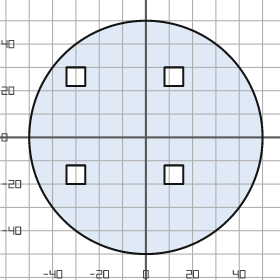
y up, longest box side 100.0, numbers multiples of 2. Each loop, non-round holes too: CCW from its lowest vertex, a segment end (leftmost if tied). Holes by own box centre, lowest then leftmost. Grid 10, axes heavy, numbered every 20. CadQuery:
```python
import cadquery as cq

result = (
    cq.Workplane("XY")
    .moveTo(0.0, 0.0)
    .circle(50.0)
    .moveTo(-34.0, -20.0)
    .lineTo(-26.0, -20.0)
    .lineTo(-26.0, -12.0)
    .lineTo(-34.0, -12.0)
    .close()
    .moveTo(8.0, -20.0)
    .lineTo(16.0, -20.0)
    .lineTo(16.0, -12.0)
    .lineTo(8.0, -12.0)
    .close()
    .moveTo(-34.0, 22.0)
    .lineTo(-26.0, 22.0)
    .lineTo(-26.0, 30.0)
    .lineTo(-34.0, 30.0)
    .close()
    .moveTo(8.0, 22.0)
    .lineTo(16.0, 22.0)
    .lineTo(16.0, 30.0)
    .lineTo(8.0, 30.0)
    .close()
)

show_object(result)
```